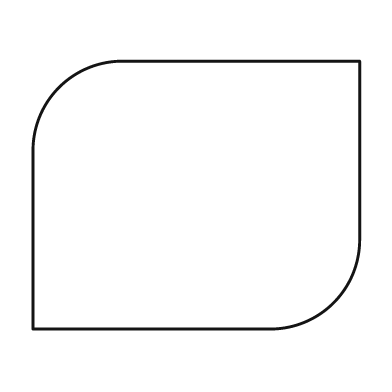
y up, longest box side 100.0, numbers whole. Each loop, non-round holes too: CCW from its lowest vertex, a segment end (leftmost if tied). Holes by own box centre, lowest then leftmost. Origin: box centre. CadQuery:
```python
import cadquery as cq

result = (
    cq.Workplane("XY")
    .moveTo(-50.0, -41.0)
    .lineTo(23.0, -41.0)
    .threePointArc((42.0, -33.0), (50.0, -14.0))
    .lineTo(50.0, 41.0)
    .lineTo(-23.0, 41.0)
    .threePointArc((-42.0, 33.0), (-50.0, 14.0))
    .close()
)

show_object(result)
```